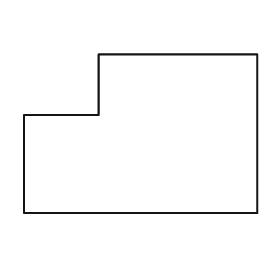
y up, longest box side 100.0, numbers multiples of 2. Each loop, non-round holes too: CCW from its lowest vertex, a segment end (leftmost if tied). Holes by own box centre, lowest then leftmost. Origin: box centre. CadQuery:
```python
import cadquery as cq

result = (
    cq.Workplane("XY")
    .moveTo(-50.0, -34.0)
    .lineTo(50.0, -34.0)
    .lineTo(50.0, 34.0)
    .lineTo(-18.0, 34.0)
    .lineTo(-18.0, 8.0)
    .lineTo(-50.0, 8.0)
    .close()
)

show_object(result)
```